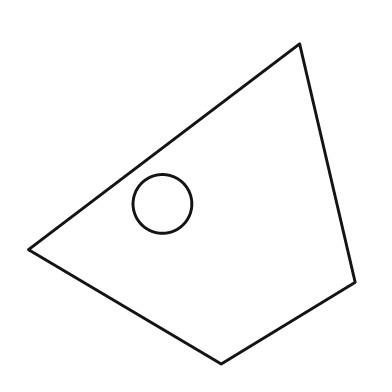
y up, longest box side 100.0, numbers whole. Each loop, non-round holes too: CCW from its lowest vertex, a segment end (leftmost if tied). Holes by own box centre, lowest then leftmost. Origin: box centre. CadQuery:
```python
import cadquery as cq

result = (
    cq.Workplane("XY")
    .moveTo(9.0, -49.0)
    .lineTo(50.0, -24.0)
    .lineTo(33.0, 49.0)
    .lineTo(-50.0, -14.0)
    .close()
    .moveTo(-9.0, 0.0)
    .circle(9.0)
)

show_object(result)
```